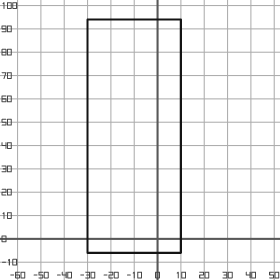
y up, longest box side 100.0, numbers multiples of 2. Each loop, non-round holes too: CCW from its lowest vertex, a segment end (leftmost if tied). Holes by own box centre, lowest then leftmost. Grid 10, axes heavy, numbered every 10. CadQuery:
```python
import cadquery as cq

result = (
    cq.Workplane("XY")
    .moveTo(-30.0, -6.0)
    .lineTo(10.0, -6.0)
    .lineTo(10.0, 94.0)
    .lineTo(-30.0, 94.0)
    .close()
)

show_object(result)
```